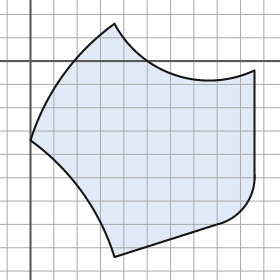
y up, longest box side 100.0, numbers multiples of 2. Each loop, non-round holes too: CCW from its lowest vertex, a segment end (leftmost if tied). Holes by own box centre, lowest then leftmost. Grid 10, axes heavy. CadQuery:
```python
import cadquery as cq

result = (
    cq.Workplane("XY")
    .moveTo(36.0, -84.0)
    .lineTo(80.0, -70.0)
    .threePointArc((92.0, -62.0), (96.0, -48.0))
    .lineTo(96.0, -4.0)
    .threePointArc((62.0, -6.0), (36.0, 16.0))
    .threePointArc((14.0, -6.0), (0.0, -34.0))
    .threePointArc((22.0, -56.0), (36.0, -84.0))
    .close()
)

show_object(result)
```